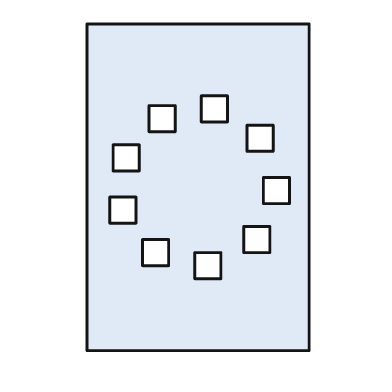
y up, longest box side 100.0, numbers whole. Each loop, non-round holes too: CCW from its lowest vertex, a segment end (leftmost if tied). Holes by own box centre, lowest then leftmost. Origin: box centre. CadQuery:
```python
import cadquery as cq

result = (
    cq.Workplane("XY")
    .moveTo(-34.0, -50.0)
    .lineTo(34.0, -50.0)
    .lineTo(34.0, 50.0)
    .lineTo(-34.0, 50.0)
    .close()
    .moveTo(-1.0, -28.0)
    .lineTo(7.0, -28.0)
    .lineTo(7.0, -20.0)
    .lineTo(-1.0, -20.0)
    .close()
    .moveTo(-17.0, -24.0)
    .lineTo(-9.0, -24.0)
    .lineTo(-9.0, -16.0)
    .lineTo(-17.0, -16.0)
    .close()
    .moveTo(14.0, -20.0)
    .lineTo(22.0, -20.0)
    .lineTo(22.0, -12.0)
    .lineTo(14.0, -12.0)
    .close()
    .moveTo(-27.0, -11.0)
    .lineTo(-19.0, -11.0)
    .lineTo(-19.0, -3.0)
    .lineTo(-27.0, -3.0)
    .close()
    .moveTo(20.0, -5.0)
    .lineTo(28.0, -5.0)
    .lineTo(28.0, 3.0)
    .lineTo(20.0, 3.0)
    .close()
    .moveTo(-26.0, 5.0)
    .lineTo(-18.0, 5.0)
    .lineTo(-18.0, 13.0)
    .lineTo(-26.0, 13.0)
    .close()
    .moveTo(15.0, 11.0)
    .lineTo(23.0, 11.0)
    .lineTo(23.0, 19.0)
    .lineTo(15.0, 19.0)
    .close()
    .moveTo(-15.0, 17.0)
    .lineTo(-7.0, 17.0)
    .lineTo(-7.0, 25.0)
    .lineTo(-15.0, 25.0)
    .close()
    .moveTo(1.0, 20.0)
    .lineTo(9.0, 20.0)
    .lineTo(9.0, 28.0)
    .lineTo(1.0, 28.0)
    .close()
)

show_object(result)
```